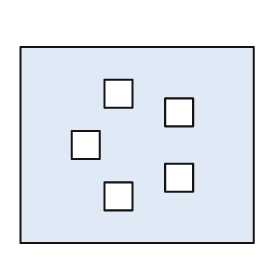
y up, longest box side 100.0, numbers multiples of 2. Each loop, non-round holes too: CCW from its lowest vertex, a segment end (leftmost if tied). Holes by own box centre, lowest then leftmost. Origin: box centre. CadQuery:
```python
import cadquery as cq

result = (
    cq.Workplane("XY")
    .moveTo(-50.0, -42.0)
    .lineTo(50.0, -42.0)
    .lineTo(50.0, 42.0)
    .lineTo(-50.0, 42.0)
    .close()
    .moveTo(-14.0, -28.0)
    .lineTo(-2.0, -28.0)
    .lineTo(-2.0, -16.0)
    .lineTo(-14.0, -16.0)
    .close()
    .moveTo(12.0, -20.0)
    .lineTo(24.0, -20.0)
    .lineTo(24.0, -8.0)
    .lineTo(12.0, -8.0)
    .close()
    .moveTo(-28.0, -6.0)
    .lineTo(-16.0, -6.0)
    .lineTo(-16.0, 6.0)
    .lineTo(-28.0, 6.0)
    .close()
    .moveTo(12.0, 8.0)
    .lineTo(24.0, 8.0)
    .lineTo(24.0, 20.0)
    .lineTo(12.0, 20.0)
    .close()
    .moveTo(-14.0, 16.0)
    .lineTo(-2.0, 16.0)
    .lineTo(-2.0, 28.0)
    .lineTo(-14.0, 28.0)
    .close()
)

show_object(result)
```